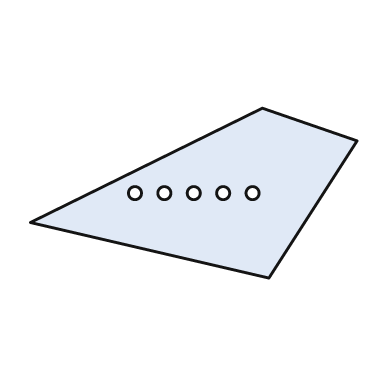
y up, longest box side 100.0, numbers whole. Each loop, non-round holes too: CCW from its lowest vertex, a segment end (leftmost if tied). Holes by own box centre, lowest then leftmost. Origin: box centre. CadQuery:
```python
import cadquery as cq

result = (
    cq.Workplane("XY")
    .moveTo(23.0, -26.0)
    .lineTo(50.0, 16.0)
    .lineTo(21.0, 26.0)
    .lineTo(-50.0, -9.0)
    .close()
    .moveTo(-18.0, 0.0)
    .circle(2.0)
    .moveTo(-9.0, 0.0)
    .circle(2.0)
    .moveTo(0.0, 0.0)
    .circle(2.0)
    .moveTo(9.0, 0.0)
    .circle(2.0)
    .moveTo(18.0, 0.0)
    .circle(2.0)
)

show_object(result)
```